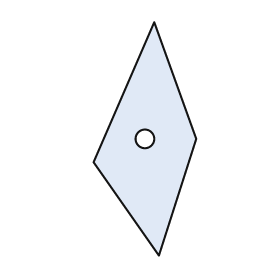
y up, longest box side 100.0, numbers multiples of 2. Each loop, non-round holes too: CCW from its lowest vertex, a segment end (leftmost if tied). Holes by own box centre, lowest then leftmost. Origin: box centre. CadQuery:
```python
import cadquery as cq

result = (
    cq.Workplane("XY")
    .moveTo(6.0, -50.0)
    .lineTo(22.0, 0.0)
    .lineTo(4.0, 50.0)
    .lineTo(-22.0, -10.0)
    .close()
    .moveTo(0.0, 0.0)
    .circle(4.0)
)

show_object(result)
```